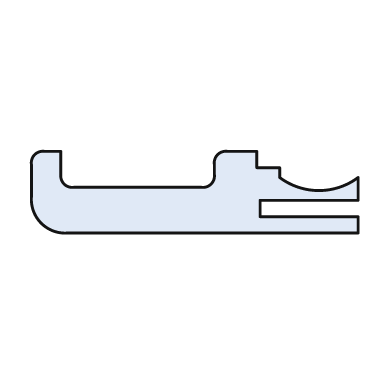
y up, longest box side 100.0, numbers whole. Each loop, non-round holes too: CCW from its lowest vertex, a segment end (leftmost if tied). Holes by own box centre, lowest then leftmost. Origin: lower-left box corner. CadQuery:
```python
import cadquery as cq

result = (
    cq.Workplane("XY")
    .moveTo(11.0, 0.0)
    .lineTo(100.0, 0.0)
    .lineTo(100.0, 5.0)
    .lineTo(70.0, 5.0)
    .lineTo(70.0, 10.0)
    .lineTo(100.0, 10.0)
    .lineTo(100.0, 17.0)
    .threePointArc((88.0, 13.0), (76.0, 17.0))
    .lineTo(76.0, 20.0)
    .lineTo(69.0, 20.0)
    .lineTo(69.0, 25.0)
    .lineTo(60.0, 25.0)
    .threePointArc((57.0, 24.0), (56.0, 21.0))
    .lineTo(56.0, 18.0)
    .threePointArc((55.0, 15.0), (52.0, 14.0))
    .lineTo(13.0, 14.0)
    .threePointArc((10.0, 15.0), (9.0, 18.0))
    .lineTo(9.0, 25.0)
    .lineTo(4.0, 25.0)
    .threePointArc((1.0, 24.0), (0.0, 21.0))
    .lineTo(0.0, 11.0)
    .threePointArc((3.0, 3.0), (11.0, 0.0))
    .close()
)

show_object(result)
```